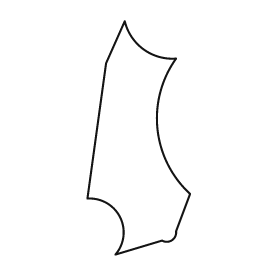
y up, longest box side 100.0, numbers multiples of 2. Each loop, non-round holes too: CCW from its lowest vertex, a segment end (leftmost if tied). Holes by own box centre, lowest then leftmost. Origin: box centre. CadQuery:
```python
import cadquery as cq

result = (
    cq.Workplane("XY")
    .moveTo(-10.0, -50.0)
    .lineTo(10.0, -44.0)
    .threePointArc((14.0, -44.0), (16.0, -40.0))
    .lineTo(22.0, -24.0)
    .threePointArc((8.0, 4.0), (16.0, 34.0))
    .threePointArc((2.0, 38.0), (-6.0, 50.0))
    .lineTo(-14.0, 32.0)
    .lineTo(-22.0, -26.0)
    .threePointArc((-8.0, -34.0), (-10.0, -50.0))
    .close()
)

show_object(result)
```